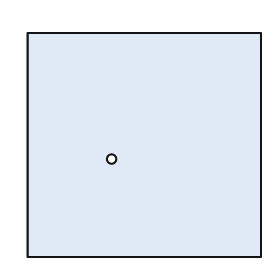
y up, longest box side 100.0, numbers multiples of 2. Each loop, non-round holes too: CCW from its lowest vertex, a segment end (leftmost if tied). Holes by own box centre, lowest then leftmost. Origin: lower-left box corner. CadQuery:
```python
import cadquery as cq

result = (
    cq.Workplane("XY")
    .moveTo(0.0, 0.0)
    .lineTo(100.0, 0.0)
    .lineTo(100.0, 96.0)
    .lineTo(0.0, 96.0)
    .close()
    .moveTo(36.0, 42.0)
    .circle(2.0)
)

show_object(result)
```